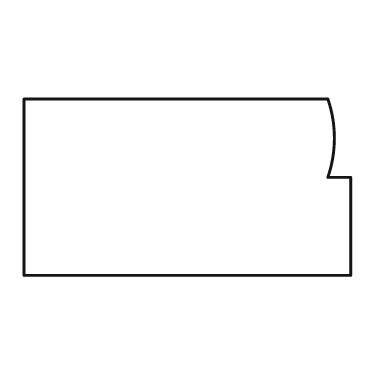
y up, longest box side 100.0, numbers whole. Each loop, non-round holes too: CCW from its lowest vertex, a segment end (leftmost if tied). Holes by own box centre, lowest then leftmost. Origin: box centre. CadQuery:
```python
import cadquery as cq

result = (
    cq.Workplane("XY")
    .moveTo(-50.0, -27.0)
    .lineTo(50.0, -27.0)
    .lineTo(50.0, 3.0)
    .lineTo(43.0, 3.0)
    .threePointArc((45.0, 15.0), (43.0, 27.0))
    .lineTo(-50.0, 27.0)
    .close()
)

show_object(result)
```